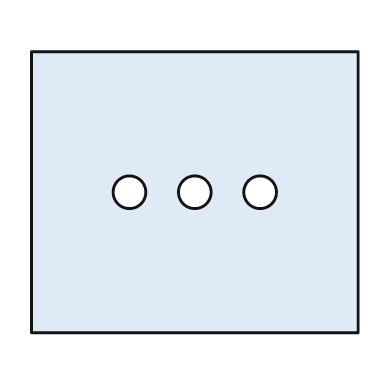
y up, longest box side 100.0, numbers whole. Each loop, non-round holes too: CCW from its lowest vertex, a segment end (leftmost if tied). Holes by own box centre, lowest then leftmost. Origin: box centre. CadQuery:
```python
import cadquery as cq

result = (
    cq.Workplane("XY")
    .moveTo(-50.0, -43.0)
    .lineTo(50.0, -43.0)
    .lineTo(50.0, 43.0)
    .lineTo(-50.0, 43.0)
    .close()
    .moveTo(-20.0, 0.0)
    .circle(5.0)
    .moveTo(0.0, 0.0)
    .circle(5.0)
    .moveTo(20.0, 0.0)
    .circle(5.0)
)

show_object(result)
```